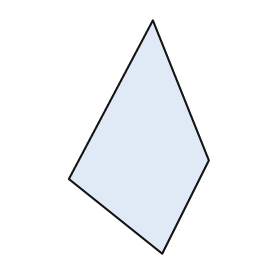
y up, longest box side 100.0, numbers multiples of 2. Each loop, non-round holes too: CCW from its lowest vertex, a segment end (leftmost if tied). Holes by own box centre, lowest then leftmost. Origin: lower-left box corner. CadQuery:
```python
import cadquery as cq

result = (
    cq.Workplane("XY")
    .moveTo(40.0, 0.0)
    .lineTo(60.0, 40.0)
    .lineTo(36.0, 100.0)
    .lineTo(0.0, 32.0)
    .close()
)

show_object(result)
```